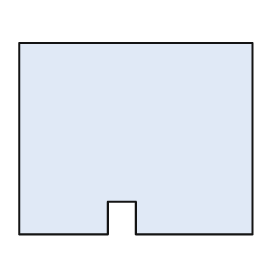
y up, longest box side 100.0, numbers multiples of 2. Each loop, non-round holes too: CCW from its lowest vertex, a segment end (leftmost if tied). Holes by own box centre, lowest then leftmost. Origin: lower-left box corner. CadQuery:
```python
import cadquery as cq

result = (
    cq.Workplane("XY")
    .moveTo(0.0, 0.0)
    .lineTo(38.0, 0.0)
    .lineTo(38.0, 14.0)
    .lineTo(50.0, 14.0)
    .lineTo(50.0, 0.0)
    .lineTo(100.0, 0.0)
    .lineTo(100.0, 82.0)
    .lineTo(0.0, 82.0)
    .close()
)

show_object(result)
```